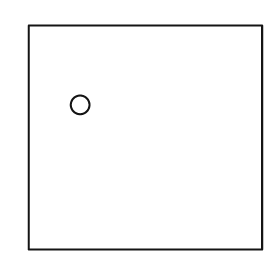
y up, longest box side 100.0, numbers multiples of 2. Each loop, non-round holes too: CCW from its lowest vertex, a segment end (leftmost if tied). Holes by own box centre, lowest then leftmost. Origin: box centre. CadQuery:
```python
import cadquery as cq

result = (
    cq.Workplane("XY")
    .moveTo(-50.0, -48.0)
    .lineTo(50.0, -48.0)
    .lineTo(50.0, 48.0)
    .lineTo(-50.0, 48.0)
    .close()
    .moveTo(-28.0, 14.0)
    .circle(4.0)
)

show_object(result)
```